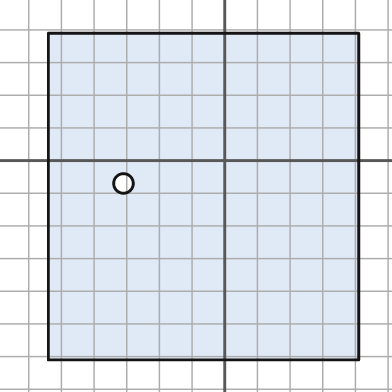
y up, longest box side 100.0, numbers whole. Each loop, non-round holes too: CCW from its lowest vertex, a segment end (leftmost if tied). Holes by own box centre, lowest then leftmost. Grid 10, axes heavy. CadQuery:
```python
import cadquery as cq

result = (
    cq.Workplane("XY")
    .moveTo(-54.0, -61.0)
    .lineTo(41.0, -61.0)
    .lineTo(41.0, 39.0)
    .lineTo(-54.0, 39.0)
    .close()
    .moveTo(-31.0, -7.0)
    .circle(3.0)
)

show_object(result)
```